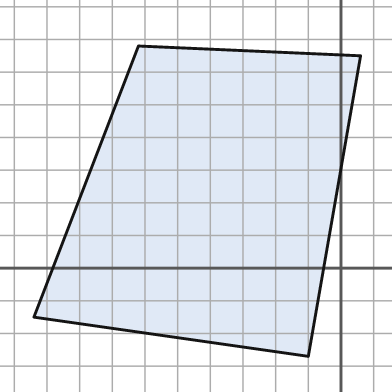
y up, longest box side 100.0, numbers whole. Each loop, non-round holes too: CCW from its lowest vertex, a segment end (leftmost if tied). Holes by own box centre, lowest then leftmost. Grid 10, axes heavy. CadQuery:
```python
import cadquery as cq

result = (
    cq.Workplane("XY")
    .moveTo(-10.0, -27.0)
    .lineTo(6.0, 65.0)
    .lineTo(-62.0, 68.0)
    .lineTo(-94.0, -15.0)
    .close()
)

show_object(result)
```